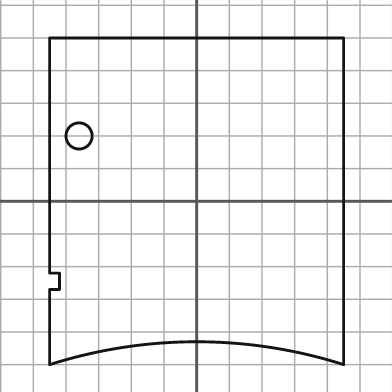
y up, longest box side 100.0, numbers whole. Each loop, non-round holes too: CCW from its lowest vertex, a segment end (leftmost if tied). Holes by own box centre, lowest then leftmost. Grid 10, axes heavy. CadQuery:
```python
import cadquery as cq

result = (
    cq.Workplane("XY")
    .moveTo(-45.0, -50.0)
    .threePointArc((0.0, -43.0), (45.0, -50.0))
    .lineTo(45.0, 50.0)
    .lineTo(-45.0, 50.0)
    .lineTo(-45.0, -22.0)
    .lineTo(-42.0, -22.0)
    .lineTo(-42.0, -27.0)
    .lineTo(-45.0, -27.0)
    .close()
    .moveTo(-36.0, 20.0)
    .circle(4.0)
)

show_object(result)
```